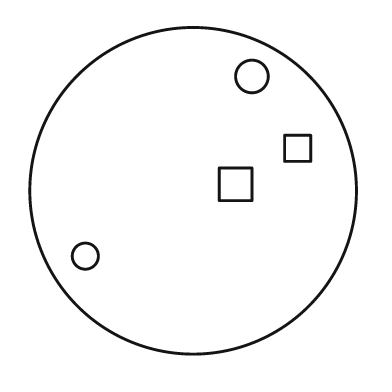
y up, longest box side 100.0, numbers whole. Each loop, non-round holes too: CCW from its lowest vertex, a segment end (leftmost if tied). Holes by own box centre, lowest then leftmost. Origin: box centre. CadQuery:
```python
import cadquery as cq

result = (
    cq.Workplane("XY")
    .moveTo(0.0, 0.0)
    .circle(50.0)
    .moveTo(-33.0, -20.0)
    .circle(4.0)
    .moveTo(8.0, -3.0)
    .lineTo(18.0, -3.0)
    .lineTo(18.0, 7.0)
    .lineTo(8.0, 7.0)
    .close()
    .moveTo(28.0, 9.0)
    .lineTo(36.0, 9.0)
    .lineTo(36.0, 17.0)
    .lineTo(28.0, 17.0)
    .close()
    .moveTo(18.0, 35.0)
    .circle(5.0)
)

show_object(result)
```